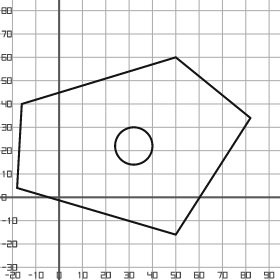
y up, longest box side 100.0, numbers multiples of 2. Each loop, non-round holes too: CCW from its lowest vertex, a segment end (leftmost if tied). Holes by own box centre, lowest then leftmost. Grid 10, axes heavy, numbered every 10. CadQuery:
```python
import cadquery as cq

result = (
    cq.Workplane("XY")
    .moveTo(50.0, -16.0)
    .lineTo(82.0, 34.0)
    .lineTo(50.0, 60.0)
    .lineTo(-16.0, 40.0)
    .lineTo(-18.0, 4.0)
    .close()
    .moveTo(32.0, 22.0)
    .circle(8.0)
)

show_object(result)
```